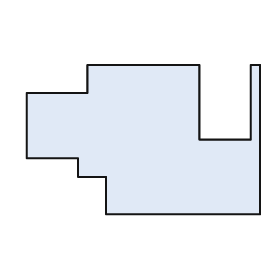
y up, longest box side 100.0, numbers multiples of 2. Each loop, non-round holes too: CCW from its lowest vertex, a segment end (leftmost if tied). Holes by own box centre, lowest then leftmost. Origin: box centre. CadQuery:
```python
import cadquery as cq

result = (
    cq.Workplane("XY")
    .moveTo(-16.0, -32.0)
    .lineTo(50.0, -32.0)
    .lineTo(50.0, 32.0)
    .lineTo(46.0, 32.0)
    .lineTo(46.0, 0.0)
    .lineTo(24.0, 0.0)
    .lineTo(24.0, 32.0)
    .lineTo(-24.0, 32.0)
    .lineTo(-24.0, 20.0)
    .lineTo(-50.0, 20.0)
    .lineTo(-50.0, -8.0)
    .lineTo(-28.0, -8.0)
    .lineTo(-28.0, -16.0)
    .lineTo(-16.0, -16.0)
    .close()
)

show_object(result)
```